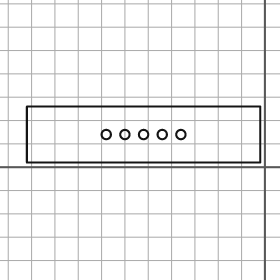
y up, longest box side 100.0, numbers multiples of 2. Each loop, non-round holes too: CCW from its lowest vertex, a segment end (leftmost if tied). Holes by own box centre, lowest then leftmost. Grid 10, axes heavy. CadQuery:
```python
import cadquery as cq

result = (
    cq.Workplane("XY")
    .moveTo(-102.0, 2.0)
    .lineTo(-2.0, 2.0)
    .lineTo(-2.0, 26.0)
    .lineTo(-102.0, 26.0)
    .close()
    .moveTo(-68.0, 14.0)
    .circle(2.0)
    .moveTo(-60.0, 14.0)
    .circle(2.0)
    .moveTo(-52.0, 14.0)
    .circle(2.0)
    .moveTo(-44.0, 14.0)
    .circle(2.0)
    .moveTo(-36.0, 14.0)
    .circle(2.0)
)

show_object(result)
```